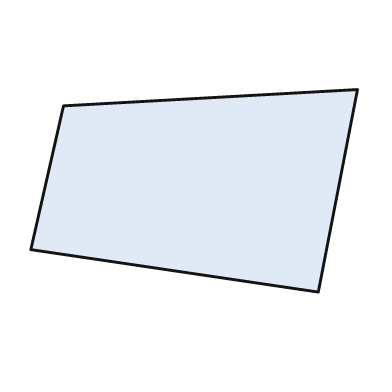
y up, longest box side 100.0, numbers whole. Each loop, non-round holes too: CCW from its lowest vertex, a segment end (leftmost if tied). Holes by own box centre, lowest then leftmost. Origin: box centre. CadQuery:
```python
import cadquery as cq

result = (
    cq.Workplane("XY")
    .moveTo(38.0, -31.0)
    .lineTo(50.0, 31.0)
    .lineTo(-40.0, 26.0)
    .lineTo(-50.0, -18.0)
    .close()
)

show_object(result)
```